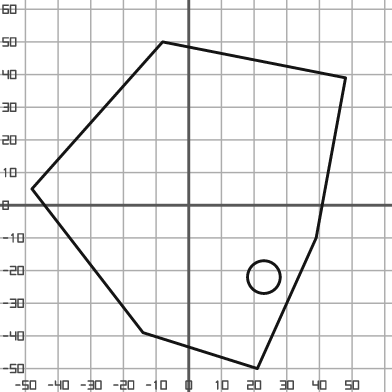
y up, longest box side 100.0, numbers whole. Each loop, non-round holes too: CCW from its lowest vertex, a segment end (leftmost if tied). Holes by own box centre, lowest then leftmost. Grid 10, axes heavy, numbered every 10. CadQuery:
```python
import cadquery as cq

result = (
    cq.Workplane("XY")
    .moveTo(21.0, -50.0)
    .lineTo(39.0, -10.0)
    .lineTo(48.0, 39.0)
    .lineTo(-8.0, 50.0)
    .lineTo(-48.0, 5.0)
    .lineTo(-14.0, -39.0)
    .close()
    .moveTo(23.0, -22.0)
    .circle(5.0)
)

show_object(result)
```